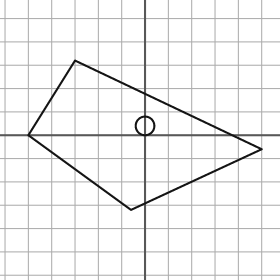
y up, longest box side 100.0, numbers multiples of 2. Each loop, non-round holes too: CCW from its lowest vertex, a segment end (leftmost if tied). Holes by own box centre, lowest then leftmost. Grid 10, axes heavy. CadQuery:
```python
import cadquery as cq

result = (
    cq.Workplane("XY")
    .moveTo(-6.0, -32.0)
    .lineTo(50.0, -6.0)
    .lineTo(-30.0, 32.0)
    .lineTo(-50.0, 0.0)
    .close()
    .moveTo(0.0, 4.0)
    .circle(4.0)
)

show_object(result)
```